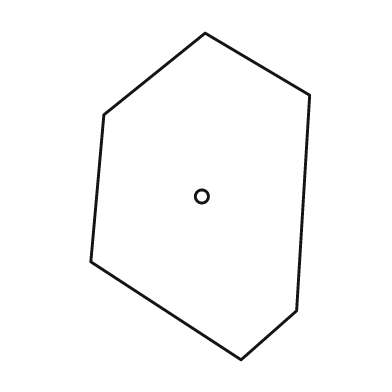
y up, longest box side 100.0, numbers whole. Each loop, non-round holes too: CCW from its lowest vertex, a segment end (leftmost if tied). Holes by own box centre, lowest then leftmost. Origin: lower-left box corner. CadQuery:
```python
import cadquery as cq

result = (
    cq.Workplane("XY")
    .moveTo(46.0, 0.0)
    .lineTo(63.0, 15.0)
    .lineTo(67.0, 81.0)
    .lineTo(35.0, 100.0)
    .lineTo(4.0, 75.0)
    .lineTo(0.0, 30.0)
    .close()
    .moveTo(34.0, 50.0)
    .circle(2.0)
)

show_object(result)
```